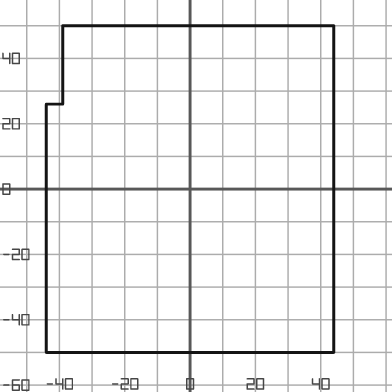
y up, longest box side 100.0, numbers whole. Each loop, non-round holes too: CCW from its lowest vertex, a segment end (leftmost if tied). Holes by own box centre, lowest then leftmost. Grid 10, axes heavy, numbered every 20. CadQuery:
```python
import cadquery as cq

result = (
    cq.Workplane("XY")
    .moveTo(-44.0, -50.0)
    .lineTo(44.0, -50.0)
    .lineTo(44.0, 50.0)
    .lineTo(-39.0, 50.0)
    .lineTo(-39.0, 26.0)
    .lineTo(-44.0, 26.0)
    .close()
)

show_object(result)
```